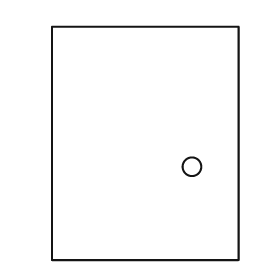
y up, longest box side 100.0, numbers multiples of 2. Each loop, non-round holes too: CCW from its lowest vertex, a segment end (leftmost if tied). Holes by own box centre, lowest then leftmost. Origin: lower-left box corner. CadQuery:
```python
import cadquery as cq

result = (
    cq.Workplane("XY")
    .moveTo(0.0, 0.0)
    .lineTo(80.0, 0.0)
    .lineTo(80.0, 100.0)
    .lineTo(0.0, 100.0)
    .close()
    .moveTo(60.0, 40.0)
    .circle(4.0)
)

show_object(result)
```